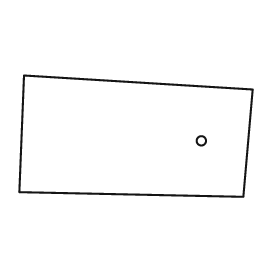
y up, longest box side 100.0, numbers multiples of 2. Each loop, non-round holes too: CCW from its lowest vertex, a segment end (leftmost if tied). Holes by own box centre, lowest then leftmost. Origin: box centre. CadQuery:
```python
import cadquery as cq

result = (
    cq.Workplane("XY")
    .moveTo(46.0, -26.0)
    .lineTo(50.0, 20.0)
    .lineTo(-48.0, 26.0)
    .lineTo(-50.0, -24.0)
    .close()
    .moveTo(28.0, -2.0)
    .circle(2.0)
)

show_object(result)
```